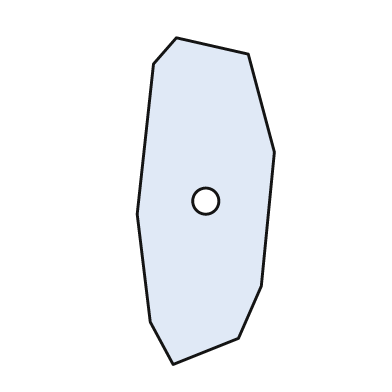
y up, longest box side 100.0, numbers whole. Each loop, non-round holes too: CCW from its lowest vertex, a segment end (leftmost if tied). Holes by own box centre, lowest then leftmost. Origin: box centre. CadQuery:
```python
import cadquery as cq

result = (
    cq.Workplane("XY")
    .moveTo(-10.0, -50.0)
    .lineTo(10.0, -42.0)
    .lineTo(17.0, -26.0)
    .lineTo(21.0, 15.0)
    .lineTo(13.0, 45.0)
    .lineTo(-9.0, 50.0)
    .lineTo(-16.0, 42.0)
    .lineTo(-21.0, -4.0)
    .lineTo(-17.0, -37.0)
    .close()
    .moveTo(0.0, 0.0)
    .circle(4.0)
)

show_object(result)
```